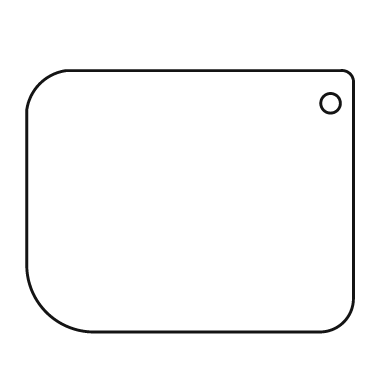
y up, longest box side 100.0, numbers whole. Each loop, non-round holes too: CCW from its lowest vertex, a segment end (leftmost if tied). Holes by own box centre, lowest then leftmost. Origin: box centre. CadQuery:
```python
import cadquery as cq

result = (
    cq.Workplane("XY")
    .moveTo(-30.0, -40.0)
    .lineTo(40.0, -40.0)
    .threePointArc((47.0, -37.0), (50.0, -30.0))
    .lineTo(50.0, 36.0)
    .threePointArc((49.0, 39.0), (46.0, 40.0))
    .lineTo(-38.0, 40.0)
    .threePointArc((-46.0, 36.0), (-50.0, 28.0))
    .lineTo(-50.0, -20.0)
    .threePointArc((-44.0, -34.0), (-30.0, -40.0))
    .close()
    .moveTo(43.0, 30.0)
    .circle(3.0)
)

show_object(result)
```